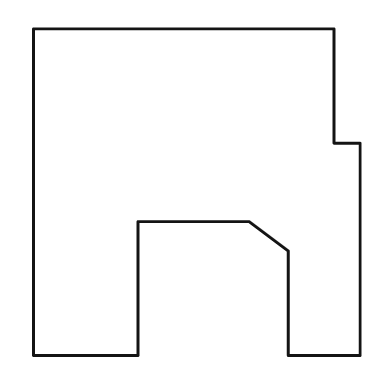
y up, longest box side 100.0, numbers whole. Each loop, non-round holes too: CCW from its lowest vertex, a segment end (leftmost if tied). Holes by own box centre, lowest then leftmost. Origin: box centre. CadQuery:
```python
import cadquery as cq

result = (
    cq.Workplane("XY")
    .moveTo(-50.0, -50.0)
    .lineTo(-18.0, -50.0)
    .lineTo(-18.0, -9.0)
    .lineTo(16.0, -9.0)
    .lineTo(28.0, -18.0)
    .lineTo(28.0, -50.0)
    .lineTo(50.0, -50.0)
    .lineTo(50.0, 15.0)
    .lineTo(42.0, 15.0)
    .lineTo(42.0, 50.0)
    .lineTo(-50.0, 50.0)
    .close()
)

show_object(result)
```